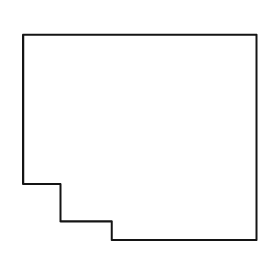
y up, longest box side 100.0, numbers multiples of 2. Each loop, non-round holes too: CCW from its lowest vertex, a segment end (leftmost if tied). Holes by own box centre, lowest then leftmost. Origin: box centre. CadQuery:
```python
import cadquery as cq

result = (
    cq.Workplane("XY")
    .moveTo(-12.0, -44.0)
    .lineTo(50.0, -44.0)
    .lineTo(50.0, 44.0)
    .lineTo(-50.0, 44.0)
    .lineTo(-50.0, -20.0)
    .lineTo(-34.0, -20.0)
    .lineTo(-34.0, -36.0)
    .lineTo(-12.0, -36.0)
    .close()
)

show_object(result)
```